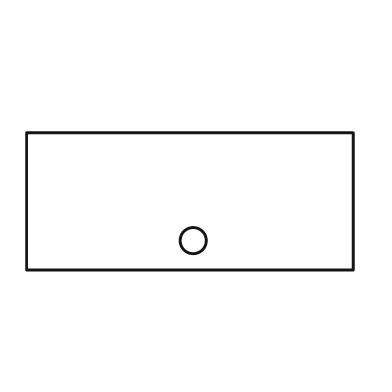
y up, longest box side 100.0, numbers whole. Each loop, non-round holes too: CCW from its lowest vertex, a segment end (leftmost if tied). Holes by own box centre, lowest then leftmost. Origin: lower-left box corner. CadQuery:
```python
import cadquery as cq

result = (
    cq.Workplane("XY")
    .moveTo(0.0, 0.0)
    .lineTo(100.0, 0.0)
    .lineTo(100.0, 42.0)
    .lineTo(0.0, 42.0)
    .close()
    .moveTo(51.0, 9.0)
    .circle(4.0)
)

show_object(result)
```